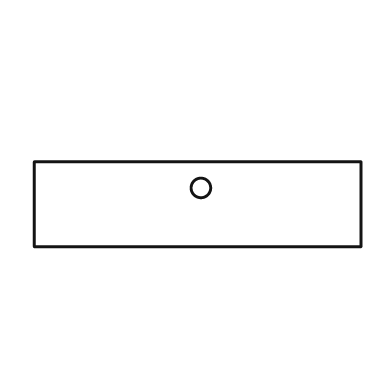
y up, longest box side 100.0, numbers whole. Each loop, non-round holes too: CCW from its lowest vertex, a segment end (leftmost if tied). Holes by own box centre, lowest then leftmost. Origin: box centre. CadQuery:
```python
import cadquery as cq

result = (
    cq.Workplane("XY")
    .moveTo(-50.0, -13.0)
    .lineTo(50.0, -13.0)
    .lineTo(50.0, 13.0)
    .lineTo(-50.0, 13.0)
    .close()
    .moveTo(1.0, 5.0)
    .circle(3.0)
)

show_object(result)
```